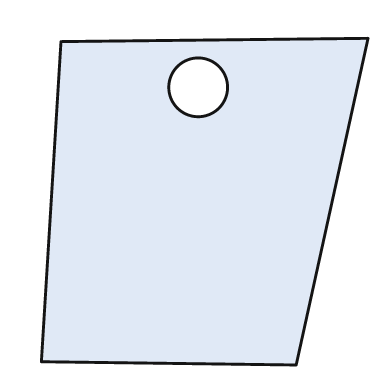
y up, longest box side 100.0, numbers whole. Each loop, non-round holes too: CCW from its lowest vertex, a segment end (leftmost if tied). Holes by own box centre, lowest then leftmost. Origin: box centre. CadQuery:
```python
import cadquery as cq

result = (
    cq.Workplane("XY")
    .moveTo(28.0, -50.0)
    .lineTo(50.0, 50.0)
    .lineTo(-44.0, 49.0)
    .lineTo(-50.0, -49.0)
    .close()
    .moveTo(-2.0, 35.0)
    .circle(9.0)
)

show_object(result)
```